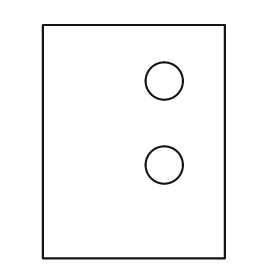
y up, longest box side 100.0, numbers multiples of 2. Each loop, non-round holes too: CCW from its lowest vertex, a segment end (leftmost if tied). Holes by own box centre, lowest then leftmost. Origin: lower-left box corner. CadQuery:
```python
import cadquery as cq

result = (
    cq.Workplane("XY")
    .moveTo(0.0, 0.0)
    .lineTo(78.0, 0.0)
    .lineTo(78.0, 100.0)
    .lineTo(0.0, 100.0)
    .close()
    .moveTo(52.0, 40.0)
    .circle(8.0)
    .moveTo(52.0, 76.0)
    .circle(8.0)
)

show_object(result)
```